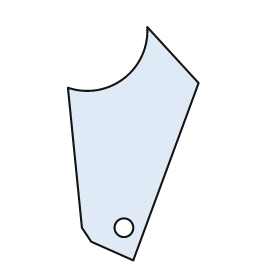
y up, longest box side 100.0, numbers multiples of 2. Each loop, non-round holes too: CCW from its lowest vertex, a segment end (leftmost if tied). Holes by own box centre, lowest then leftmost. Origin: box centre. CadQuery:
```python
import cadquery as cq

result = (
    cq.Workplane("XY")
    .moveTo(0.0, -50.0)
    .lineTo(28.0, 26.0)
    .lineTo(6.0, 50.0)
    .threePointArc((-4.0, 28.0), (-28.0, 24.0))
    .lineTo(-22.0, -36.0)
    .lineTo(-18.0, -42.0)
    .close()
    .moveTo(-4.0, -36.0)
    .circle(4.0)
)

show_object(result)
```